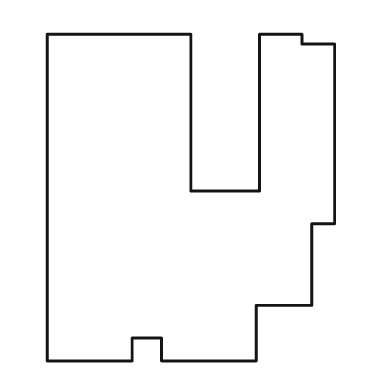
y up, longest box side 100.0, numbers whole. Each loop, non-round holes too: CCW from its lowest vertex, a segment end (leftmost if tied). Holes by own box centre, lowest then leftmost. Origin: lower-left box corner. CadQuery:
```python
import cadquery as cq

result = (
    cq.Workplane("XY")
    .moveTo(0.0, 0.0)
    .lineTo(26.0, 0.0)
    .lineTo(26.0, 7.0)
    .lineTo(35.0, 7.0)
    .lineTo(35.0, 0.0)
    .lineTo(64.0, 0.0)
    .lineTo(64.0, 17.0)
    .lineTo(81.0, 17.0)
    .lineTo(81.0, 42.0)
    .lineTo(88.0, 42.0)
    .lineTo(88.0, 97.0)
    .lineTo(78.0, 97.0)
    .lineTo(78.0, 100.0)
    .lineTo(65.0, 100.0)
    .lineTo(65.0, 52.0)
    .lineTo(44.0, 52.0)
    .lineTo(44.0, 100.0)
    .lineTo(0.0, 100.0)
    .close()
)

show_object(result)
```